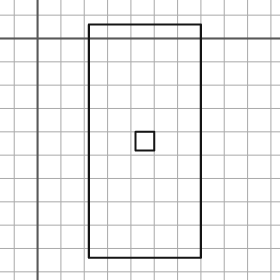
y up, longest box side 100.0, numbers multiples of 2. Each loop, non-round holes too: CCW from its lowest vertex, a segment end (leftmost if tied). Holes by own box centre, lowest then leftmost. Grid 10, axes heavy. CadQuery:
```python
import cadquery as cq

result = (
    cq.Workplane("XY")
    .moveTo(22.0, -94.0)
    .lineTo(70.0, -94.0)
    .lineTo(70.0, 6.0)
    .lineTo(22.0, 6.0)
    .close()
    .moveTo(42.0, -48.0)
    .lineTo(50.0, -48.0)
    .lineTo(50.0, -40.0)
    .lineTo(42.0, -40.0)
    .close()
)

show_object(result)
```